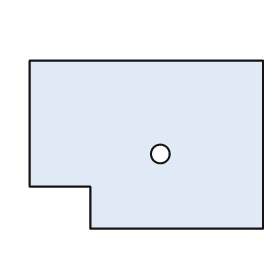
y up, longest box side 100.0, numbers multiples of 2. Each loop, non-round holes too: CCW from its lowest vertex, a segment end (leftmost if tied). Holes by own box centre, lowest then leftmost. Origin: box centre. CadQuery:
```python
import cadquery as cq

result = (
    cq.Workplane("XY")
    .moveTo(-24.0, -36.0)
    .lineTo(50.0, -36.0)
    .lineTo(50.0, 36.0)
    .lineTo(-50.0, 36.0)
    .lineTo(-50.0, -18.0)
    .lineTo(-24.0, -18.0)
    .close()
    .moveTo(6.0, -4.0)
    .circle(4.0)
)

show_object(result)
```